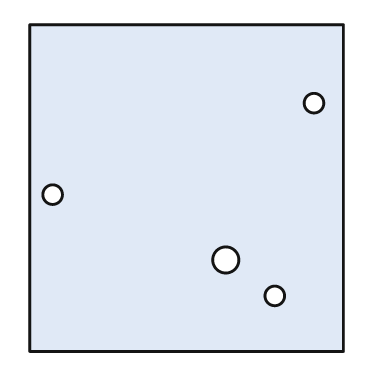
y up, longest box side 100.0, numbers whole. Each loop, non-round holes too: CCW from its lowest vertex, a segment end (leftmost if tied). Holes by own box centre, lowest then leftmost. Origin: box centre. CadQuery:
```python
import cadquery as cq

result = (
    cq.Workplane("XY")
    .moveTo(-48.0, -50.0)
    .lineTo(48.0, -50.0)
    .lineTo(48.0, 50.0)
    .lineTo(-48.0, 50.0)
    .close()
    .moveTo(27.0, -33.0)
    .circle(3.0)
    .moveTo(12.0, -22.0)
    .circle(4.0)
    .moveTo(-41.0, -2.0)
    .circle(3.0)
    .moveTo(39.0, 26.0)
    .circle(3.0)
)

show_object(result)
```